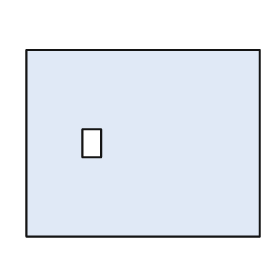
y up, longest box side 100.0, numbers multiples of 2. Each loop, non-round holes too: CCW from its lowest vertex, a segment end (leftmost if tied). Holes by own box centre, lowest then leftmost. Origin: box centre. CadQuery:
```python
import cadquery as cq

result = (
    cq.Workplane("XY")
    .moveTo(-50.0, -40.0)
    .lineTo(50.0, -40.0)
    .lineTo(50.0, 40.0)
    .lineTo(-50.0, 40.0)
    .close()
    .moveTo(-26.0, -6.0)
    .lineTo(-18.0, -6.0)
    .lineTo(-18.0, 6.0)
    .lineTo(-26.0, 6.0)
    .close()
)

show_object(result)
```